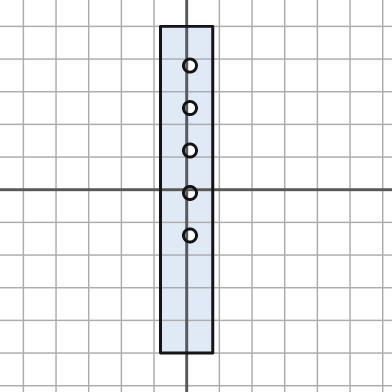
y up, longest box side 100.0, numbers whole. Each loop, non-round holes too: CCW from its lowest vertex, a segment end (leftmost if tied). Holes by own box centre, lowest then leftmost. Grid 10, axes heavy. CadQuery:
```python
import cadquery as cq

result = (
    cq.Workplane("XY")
    .moveTo(-8.0, -50.0)
    .lineTo(8.0, -50.0)
    .lineTo(8.0, 50.0)
    .lineTo(-8.0, 50.0)
    .close()
    .moveTo(1.0, -14.0)
    .circle(2.0)
    .moveTo(1.0, -1.0)
    .circle(2.0)
    .moveTo(1.0, 12.0)
    .circle(2.0)
    .moveTo(1.0, 25.0)
    .circle(2.0)
    .moveTo(1.0, 38.0)
    .circle(2.0)
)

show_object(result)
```